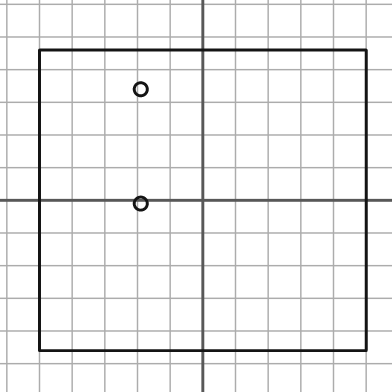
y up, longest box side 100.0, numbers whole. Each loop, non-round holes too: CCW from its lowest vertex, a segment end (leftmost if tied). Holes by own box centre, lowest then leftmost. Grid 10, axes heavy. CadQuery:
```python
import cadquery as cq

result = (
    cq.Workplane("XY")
    .moveTo(-50.0, -46.0)
    .lineTo(50.0, -46.0)
    .lineTo(50.0, 46.0)
    .lineTo(-50.0, 46.0)
    .close()
    .moveTo(-19.0, -1.0)
    .circle(2.0)
    .moveTo(-19.0, 34.0)
    .circle(2.0)
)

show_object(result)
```